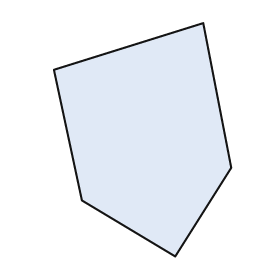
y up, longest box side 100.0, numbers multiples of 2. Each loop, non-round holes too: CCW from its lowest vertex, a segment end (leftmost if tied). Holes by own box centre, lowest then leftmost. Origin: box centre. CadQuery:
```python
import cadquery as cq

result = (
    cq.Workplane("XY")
    .moveTo(14.0, -50.0)
    .lineTo(38.0, -12.0)
    .lineTo(26.0, 50.0)
    .lineTo(-38.0, 30.0)
    .lineTo(-26.0, -26.0)
    .close()
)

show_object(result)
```